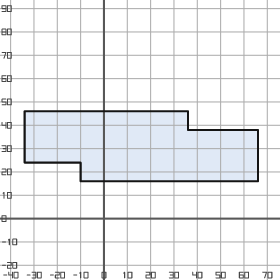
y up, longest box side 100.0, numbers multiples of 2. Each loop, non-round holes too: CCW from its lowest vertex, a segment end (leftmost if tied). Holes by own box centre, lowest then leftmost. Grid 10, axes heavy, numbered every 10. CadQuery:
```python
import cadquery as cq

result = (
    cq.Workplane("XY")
    .moveTo(-10.0, 16.0)
    .lineTo(66.0, 16.0)
    .lineTo(66.0, 38.0)
    .lineTo(36.0, 38.0)
    .lineTo(36.0, 46.0)
    .lineTo(-34.0, 46.0)
    .lineTo(-34.0, 24.0)
    .lineTo(-10.0, 24.0)
    .close()
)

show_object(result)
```